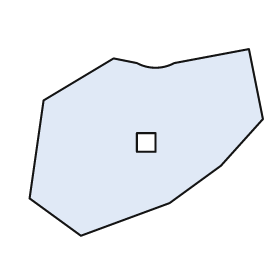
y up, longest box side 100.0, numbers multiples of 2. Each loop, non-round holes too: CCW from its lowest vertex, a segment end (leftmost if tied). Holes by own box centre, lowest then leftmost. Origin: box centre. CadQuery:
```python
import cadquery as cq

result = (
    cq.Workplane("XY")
    .moveTo(-28.0, -40.0)
    .lineTo(10.0, -26.0)
    .lineTo(32.0, -10.0)
    .lineTo(50.0, 10.0)
    .lineTo(44.0, 40.0)
    .lineTo(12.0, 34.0)
    .threePointArc((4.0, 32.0), (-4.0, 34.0))
    .lineTo(-14.0, 36.0)
    .lineTo(-44.0, 18.0)
    .lineTo(-50.0, -24.0)
    .close()
    .moveTo(-4.0, -4.0)
    .lineTo(4.0, -4.0)
    .lineTo(4.0, 4.0)
    .lineTo(-4.0, 4.0)
    .close()
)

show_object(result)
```